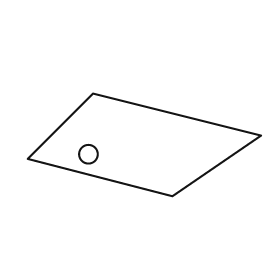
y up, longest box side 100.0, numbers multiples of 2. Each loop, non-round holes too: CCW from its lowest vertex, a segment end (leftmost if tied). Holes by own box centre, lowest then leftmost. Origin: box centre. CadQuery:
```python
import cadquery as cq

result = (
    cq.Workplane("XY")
    .moveTo(12.0, -22.0)
    .lineTo(50.0, 4.0)
    .lineTo(-22.0, 22.0)
    .lineTo(-50.0, -6.0)
    .close()
    .moveTo(-24.0, -4.0)
    .circle(4.0)
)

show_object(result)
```